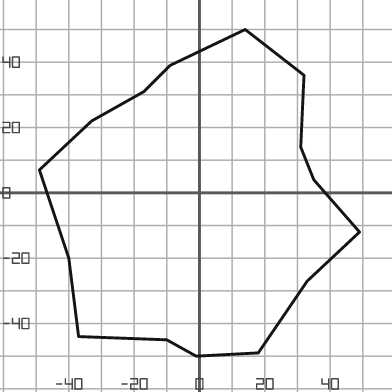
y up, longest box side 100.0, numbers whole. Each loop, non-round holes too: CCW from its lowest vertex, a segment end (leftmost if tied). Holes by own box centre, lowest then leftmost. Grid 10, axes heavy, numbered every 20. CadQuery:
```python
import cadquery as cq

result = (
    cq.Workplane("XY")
    .moveTo(-1.0, -50.0)
    .lineTo(18.0, -49.0)
    .lineTo(33.0, -27.0)
    .lineTo(49.0, -12.0)
    .lineTo(35.0, 4.0)
    .lineTo(31.0, 14.0)
    .lineTo(32.0, 36.0)
    .lineTo(14.0, 50.0)
    .lineTo(-9.0, 39.0)
    .lineTo(-17.0, 31.0)
    .lineTo(-33.0, 22.0)
    .lineTo(-49.0, 7.0)
    .lineTo(-40.0, -20.0)
    .lineTo(-37.0, -44.0)
    .lineTo(-10.0, -45.0)
    .close()
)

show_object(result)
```